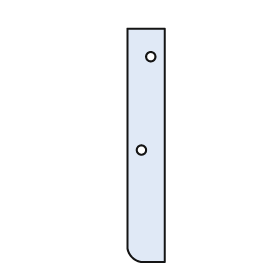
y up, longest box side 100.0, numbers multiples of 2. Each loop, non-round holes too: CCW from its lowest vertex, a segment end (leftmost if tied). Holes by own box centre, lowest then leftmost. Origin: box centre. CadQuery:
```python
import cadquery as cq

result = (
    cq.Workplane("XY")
    .moveTo(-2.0, -50.0)
    .lineTo(8.0, -50.0)
    .lineTo(8.0, 50.0)
    .lineTo(-8.0, 50.0)
    .lineTo(-8.0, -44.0)
    .threePointArc((-6.0, -48.0), (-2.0, -50.0))
    .close()
    .moveTo(-2.0, -2.0)
    .circle(2.0)
    .moveTo(2.0, 38.0)
    .circle(2.0)
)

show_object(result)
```